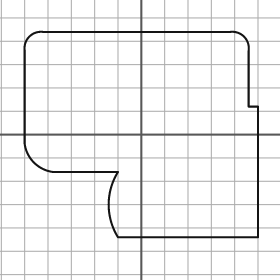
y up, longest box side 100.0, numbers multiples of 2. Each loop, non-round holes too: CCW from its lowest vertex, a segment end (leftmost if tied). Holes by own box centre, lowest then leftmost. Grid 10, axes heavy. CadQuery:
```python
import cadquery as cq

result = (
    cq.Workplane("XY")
    .moveTo(-10.0, -44.0)
    .lineTo(50.0, -44.0)
    .lineTo(50.0, 12.0)
    .lineTo(46.0, 12.0)
    .lineTo(46.0, 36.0)
    .threePointArc((44.0, 42.0), (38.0, 44.0))
    .lineTo(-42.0, 44.0)
    .threePointArc((-48.0, 42.0), (-50.0, 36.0))
    .lineTo(-50.0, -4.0)
    .threePointArc((-46.0, -12.0), (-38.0, -16.0))
    .lineTo(-10.0, -16.0)
    .threePointArc((-14.0, -30.0), (-10.0, -44.0))
    .close()
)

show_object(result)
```